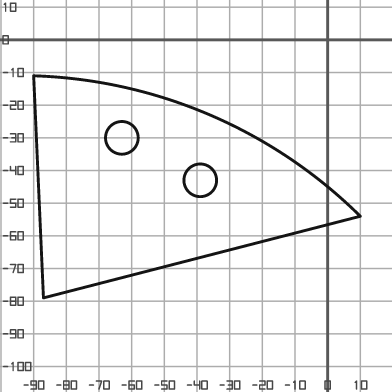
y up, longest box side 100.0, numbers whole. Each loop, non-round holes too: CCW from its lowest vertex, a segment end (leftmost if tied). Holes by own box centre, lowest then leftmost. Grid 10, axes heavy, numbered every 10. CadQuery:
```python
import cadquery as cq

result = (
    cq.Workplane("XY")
    .moveTo(-87.0, -79.0)
    .lineTo(10.0, -54.0)
    .threePointArc((-36.0, -23.0), (-90.0, -11.0))
    .close()
    .moveTo(-39.0, -43.0)
    .circle(5.0)
    .moveTo(-63.0, -30.0)
    .circle(5.0)
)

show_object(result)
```